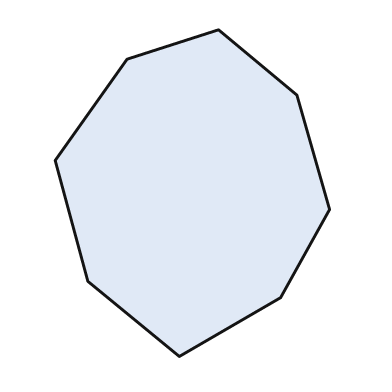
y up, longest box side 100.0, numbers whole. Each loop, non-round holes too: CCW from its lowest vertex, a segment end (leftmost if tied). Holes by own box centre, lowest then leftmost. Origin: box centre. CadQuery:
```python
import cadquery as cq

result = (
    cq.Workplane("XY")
    .moveTo(-4.0, -50.0)
    .lineTo(27.0, -32.0)
    .lineTo(42.0, -5.0)
    .lineTo(32.0, 30.0)
    .lineTo(8.0, 50.0)
    .lineTo(-20.0, 41.0)
    .lineTo(-42.0, 10.0)
    .lineTo(-32.0, -27.0)
    .close()
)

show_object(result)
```